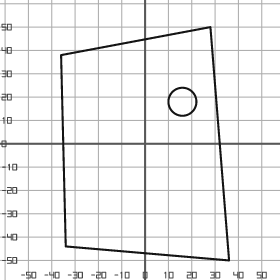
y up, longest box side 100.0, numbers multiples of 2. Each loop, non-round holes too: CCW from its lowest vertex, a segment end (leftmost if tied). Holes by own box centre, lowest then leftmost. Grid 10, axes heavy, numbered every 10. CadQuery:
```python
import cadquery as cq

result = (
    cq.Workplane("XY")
    .moveTo(36.0, -50.0)
    .lineTo(28.0, 50.0)
    .lineTo(-36.0, 38.0)
    .lineTo(-34.0, -44.0)
    .close()
    .moveTo(16.0, 18.0)
    .circle(6.0)
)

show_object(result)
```